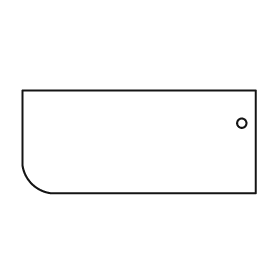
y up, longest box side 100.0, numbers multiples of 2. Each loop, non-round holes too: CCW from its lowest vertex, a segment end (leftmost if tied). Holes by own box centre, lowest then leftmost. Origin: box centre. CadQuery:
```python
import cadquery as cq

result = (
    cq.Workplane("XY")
    .moveTo(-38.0, -22.0)
    .lineTo(50.0, -22.0)
    .lineTo(50.0, 22.0)
    .lineTo(-50.0, 22.0)
    .lineTo(-50.0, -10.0)
    .threePointArc((-46.0, -18.0), (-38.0, -22.0))
    .close()
    .moveTo(44.0, 8.0)
    .circle(2.0)
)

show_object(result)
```